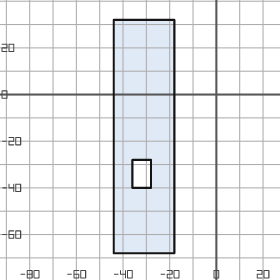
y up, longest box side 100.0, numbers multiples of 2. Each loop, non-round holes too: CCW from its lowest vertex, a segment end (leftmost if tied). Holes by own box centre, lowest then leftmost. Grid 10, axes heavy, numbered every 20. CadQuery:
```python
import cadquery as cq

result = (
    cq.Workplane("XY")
    .moveTo(-44.0, -68.0)
    .lineTo(-18.0, -68.0)
    .lineTo(-18.0, 32.0)
    .lineTo(-44.0, 32.0)
    .close()
    .moveTo(-36.0, -40.0)
    .lineTo(-28.0, -40.0)
    .lineTo(-28.0, -28.0)
    .lineTo(-36.0, -28.0)
    .close()
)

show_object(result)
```